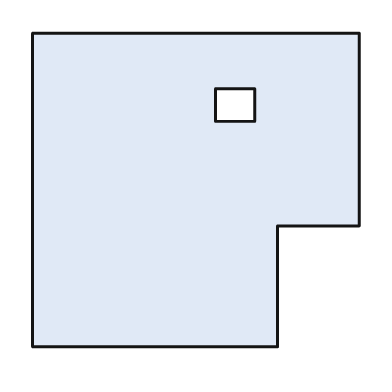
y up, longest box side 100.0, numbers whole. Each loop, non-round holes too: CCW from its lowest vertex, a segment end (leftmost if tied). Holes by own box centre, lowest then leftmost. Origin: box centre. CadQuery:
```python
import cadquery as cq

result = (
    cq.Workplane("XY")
    .moveTo(-50.0, -48.0)
    .lineTo(25.0, -48.0)
    .lineTo(25.0, -11.0)
    .lineTo(50.0, -11.0)
    .lineTo(50.0, 48.0)
    .lineTo(-50.0, 48.0)
    .close()
    .moveTo(6.0, 21.0)
    .lineTo(18.0, 21.0)
    .lineTo(18.0, 31.0)
    .lineTo(6.0, 31.0)
    .close()
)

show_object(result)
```